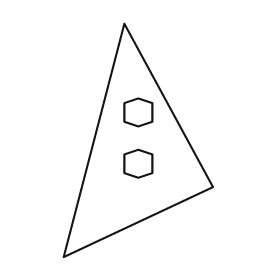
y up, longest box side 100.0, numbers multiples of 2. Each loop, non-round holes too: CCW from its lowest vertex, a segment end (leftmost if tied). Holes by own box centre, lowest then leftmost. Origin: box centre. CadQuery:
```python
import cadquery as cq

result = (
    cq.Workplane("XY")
    .moveTo(-32.0, -50.0)
    .lineTo(32.0, -20.0)
    .lineTo(-6.0, 50.0)
    .close()
    .moveTo(0.0, -16.0)
    .lineTo(6.0, -14.0)
    .lineTo(6.0, -6.0)
    .lineTo(0.0, -4.0)
    .lineTo(-6.0, -6.0)
    .lineTo(-6.0, -14.0)
    .close()
    .moveTo(0.0, 6.0)
    .lineTo(6.0, 8.0)
    .lineTo(6.0, 16.0)
    .lineTo(0.0, 18.0)
    .lineTo(-6.0, 16.0)
    .lineTo(-6.0, 8.0)
    .close()
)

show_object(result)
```